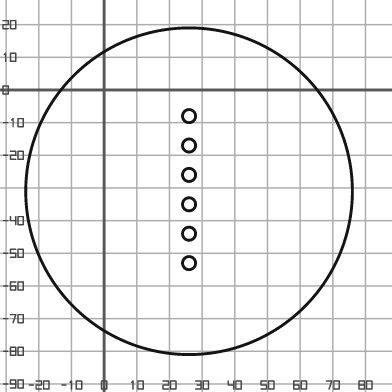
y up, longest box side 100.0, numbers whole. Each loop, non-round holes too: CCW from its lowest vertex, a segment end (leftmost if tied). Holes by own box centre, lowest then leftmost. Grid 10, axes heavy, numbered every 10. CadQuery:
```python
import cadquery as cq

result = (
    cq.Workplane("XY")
    .moveTo(26.0, -31.0)
    .circle(50.0)
    .moveTo(26.0, -53.0)
    .circle(2.0)
    .moveTo(26.0, -44.0)
    .circle(2.0)
    .moveTo(26.0, -35.0)
    .circle(2.0)
    .moveTo(26.0, -26.0)
    .circle(2.0)
    .moveTo(26.0, -17.0)
    .circle(2.0)
    .moveTo(26.0, -8.0)
    .circle(2.0)
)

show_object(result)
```